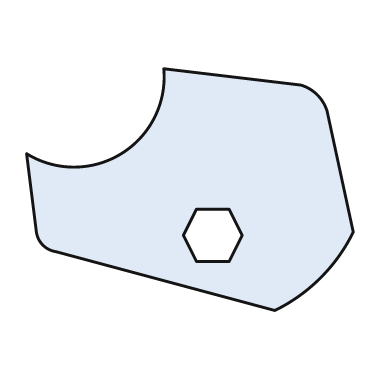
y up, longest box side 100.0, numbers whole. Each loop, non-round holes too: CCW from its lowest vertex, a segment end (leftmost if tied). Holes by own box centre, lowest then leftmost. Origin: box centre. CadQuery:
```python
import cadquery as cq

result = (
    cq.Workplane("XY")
    .moveTo(26.0, -37.0)
    .threePointArc((40.0, -27.0), (50.0, -13.0))
    .lineTo(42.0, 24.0)
    .threePointArc((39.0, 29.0), (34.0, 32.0))
    .lineTo(-8.0, 37.0)
    .threePointArc((-21.0, 11.0), (-50.0, 11.0))
    .lineTo(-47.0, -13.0)
    .threePointArc((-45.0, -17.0), (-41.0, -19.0))
    .close()
    .moveTo(2.0, -22.0)
    .lineTo(12.0, -22.0)
    .lineTo(16.0, -14.0)
    .lineTo(12.0, -6.0)
    .lineTo(2.0, -6.0)
    .lineTo(-2.0, -14.0)
    .close()
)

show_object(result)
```